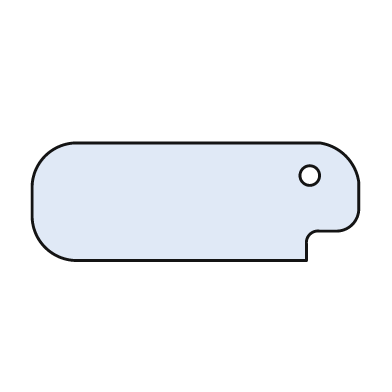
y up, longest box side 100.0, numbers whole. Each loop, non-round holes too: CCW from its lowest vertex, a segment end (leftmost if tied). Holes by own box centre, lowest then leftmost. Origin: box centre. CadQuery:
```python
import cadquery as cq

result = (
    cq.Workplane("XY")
    .moveTo(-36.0, -18.0)
    .lineTo(34.0, -18.0)
    .lineTo(34.0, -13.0)
    .threePointArc((35.0, -10.0), (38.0, -9.0))
    .lineTo(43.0, -9.0)
    .threePointArc((48.0, -7.0), (50.0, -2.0))
    .lineTo(50.0, 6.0)
    .threePointArc((46.0, 14.0), (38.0, 18.0))
    .lineTo(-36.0, 18.0)
    .threePointArc((-46.0, 14.0), (-50.0, 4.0))
    .lineTo(-50.0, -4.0)
    .threePointArc((-46.0, -14.0), (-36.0, -18.0))
    .close()
    .moveTo(35.0, 8.0)
    .circle(3.0)
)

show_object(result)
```